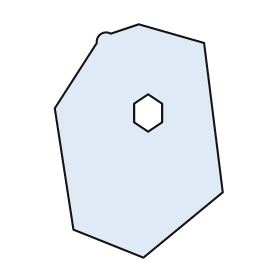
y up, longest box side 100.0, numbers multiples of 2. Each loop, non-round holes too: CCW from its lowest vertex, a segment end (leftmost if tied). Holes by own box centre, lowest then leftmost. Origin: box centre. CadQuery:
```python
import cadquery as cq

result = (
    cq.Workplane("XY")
    .moveTo(2.0, -50.0)
    .lineTo(36.0, -22.0)
    .lineTo(28.0, 42.0)
    .lineTo(0.0, 50.0)
    .lineTo(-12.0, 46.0)
    .threePointArc((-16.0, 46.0), (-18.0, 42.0))
    .lineTo(-36.0, 14.0)
    .lineTo(-28.0, -38.0)
    .close()
    .moveTo(4.0, 4.0)
    .lineTo(10.0, 8.0)
    .lineTo(10.0, 16.0)
    .lineTo(4.0, 20.0)
    .lineTo(-2.0, 16.0)
    .lineTo(-2.0, 8.0)
    .close()
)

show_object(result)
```